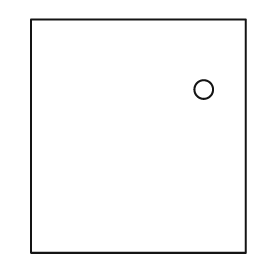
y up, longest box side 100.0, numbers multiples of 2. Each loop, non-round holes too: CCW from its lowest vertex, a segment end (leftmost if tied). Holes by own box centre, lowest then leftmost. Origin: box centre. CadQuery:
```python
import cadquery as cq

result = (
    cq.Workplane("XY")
    .moveTo(-46.0, -50.0)
    .lineTo(46.0, -50.0)
    .lineTo(46.0, 50.0)
    .lineTo(-46.0, 50.0)
    .close()
    .moveTo(28.0, 20.0)
    .circle(4.0)
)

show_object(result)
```